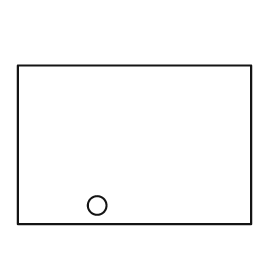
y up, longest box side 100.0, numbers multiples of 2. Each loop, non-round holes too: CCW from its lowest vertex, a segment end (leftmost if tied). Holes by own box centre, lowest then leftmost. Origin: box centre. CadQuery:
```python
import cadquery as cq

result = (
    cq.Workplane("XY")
    .moveTo(-50.0, -34.0)
    .lineTo(50.0, -34.0)
    .lineTo(50.0, 34.0)
    .lineTo(-50.0, 34.0)
    .close()
    .moveTo(-16.0, -26.0)
    .circle(4.0)
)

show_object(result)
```